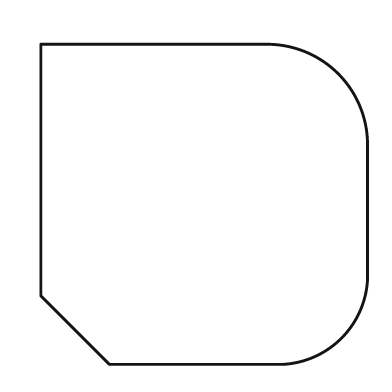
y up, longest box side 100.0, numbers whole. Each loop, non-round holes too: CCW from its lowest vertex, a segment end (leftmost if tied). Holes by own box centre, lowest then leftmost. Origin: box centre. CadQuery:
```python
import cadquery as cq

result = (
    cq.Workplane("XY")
    .moveTo(-29.0, -49.0)
    .lineTo(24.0, -49.0)
    .threePointArc((42.0, -41.0), (50.0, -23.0))
    .lineTo(50.0, 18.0)
    .threePointArc((41.0, 40.0), (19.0, 49.0))
    .lineTo(-50.0, 49.0)
    .lineTo(-50.0, -28.0)
    .close()
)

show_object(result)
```